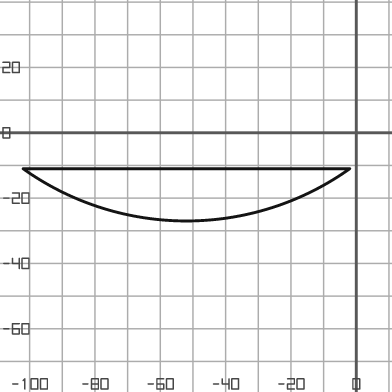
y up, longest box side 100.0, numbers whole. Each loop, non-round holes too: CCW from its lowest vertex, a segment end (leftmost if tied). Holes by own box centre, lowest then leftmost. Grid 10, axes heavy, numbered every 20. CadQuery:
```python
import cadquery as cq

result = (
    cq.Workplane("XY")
    .moveTo(-102.0, -11.0)
    .threePointArc((-52.0, -27.0), (-2.0, -11.0))
    .close()
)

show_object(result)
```